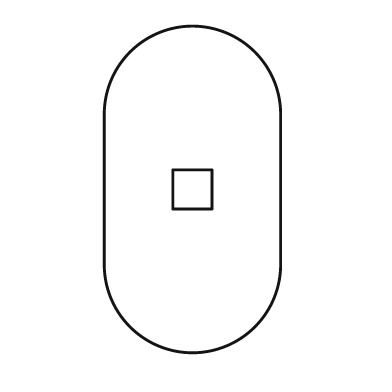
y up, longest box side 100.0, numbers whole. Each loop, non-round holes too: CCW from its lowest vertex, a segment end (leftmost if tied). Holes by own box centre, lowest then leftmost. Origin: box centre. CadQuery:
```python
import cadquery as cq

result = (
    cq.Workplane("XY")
    .moveTo(-27.0, -23.0)
    .threePointArc((0.0, -50.0), (27.0, -23.0))
    .lineTo(27.0, 23.0)
    .threePointArc((0.0, 50.0), (-27.0, 23.0))
    .close()
    .moveTo(-6.0, -6.0)
    .lineTo(6.0, -6.0)
    .lineTo(6.0, 6.0)
    .lineTo(-6.0, 6.0)
    .close()
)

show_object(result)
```